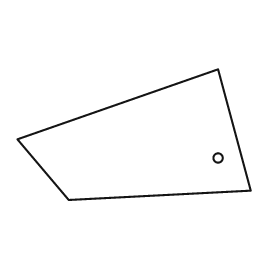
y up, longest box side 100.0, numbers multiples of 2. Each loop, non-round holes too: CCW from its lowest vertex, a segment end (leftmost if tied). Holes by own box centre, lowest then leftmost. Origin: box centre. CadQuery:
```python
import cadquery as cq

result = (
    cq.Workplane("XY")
    .moveTo(-28.0, -28.0)
    .lineTo(50.0, -24.0)
    .lineTo(36.0, 28.0)
    .lineTo(-50.0, -2.0)
    .close()
    .moveTo(36.0, -10.0)
    .circle(2.0)
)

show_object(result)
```